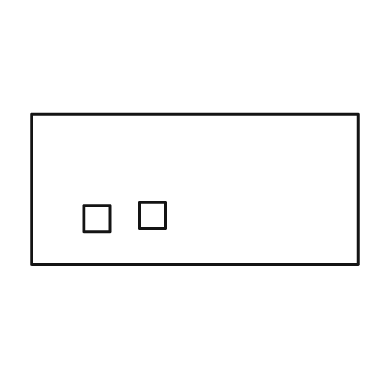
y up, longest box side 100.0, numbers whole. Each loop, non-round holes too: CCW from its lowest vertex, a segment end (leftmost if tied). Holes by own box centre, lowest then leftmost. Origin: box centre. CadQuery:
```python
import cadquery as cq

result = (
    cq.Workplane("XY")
    .moveTo(-50.0, -23.0)
    .lineTo(50.0, -23.0)
    .lineTo(50.0, 23.0)
    .lineTo(-50.0, 23.0)
    .close()
    .moveTo(-34.0, -13.0)
    .lineTo(-26.0, -13.0)
    .lineTo(-26.0, -5.0)
    .lineTo(-34.0, -5.0)
    .close()
    .moveTo(-17.0, -12.0)
    .lineTo(-9.0, -12.0)
    .lineTo(-9.0, -4.0)
    .lineTo(-17.0, -4.0)
    .close()
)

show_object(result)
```